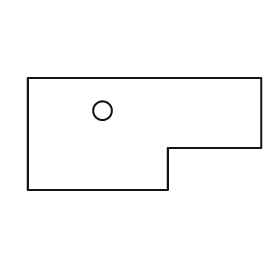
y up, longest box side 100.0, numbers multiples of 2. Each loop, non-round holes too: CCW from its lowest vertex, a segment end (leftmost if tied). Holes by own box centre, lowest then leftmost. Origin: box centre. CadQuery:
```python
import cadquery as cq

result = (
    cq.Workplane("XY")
    .moveTo(-50.0, -24.0)
    .lineTo(10.0, -24.0)
    .lineTo(10.0, -6.0)
    .lineTo(50.0, -6.0)
    .lineTo(50.0, 24.0)
    .lineTo(-50.0, 24.0)
    .close()
    .moveTo(-18.0, 10.0)
    .circle(4.0)
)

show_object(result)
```